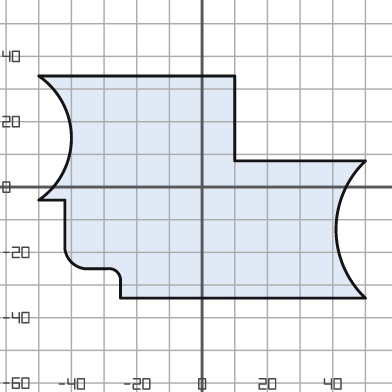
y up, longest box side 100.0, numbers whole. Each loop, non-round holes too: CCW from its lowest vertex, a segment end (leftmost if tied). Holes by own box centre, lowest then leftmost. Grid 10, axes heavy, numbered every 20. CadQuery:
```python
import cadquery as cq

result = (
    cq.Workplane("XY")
    .moveTo(-25.0, -34.0)
    .lineTo(50.0, -34.0)
    .threePointArc((41.0, -13.0), (50.0, 8.0))
    .lineTo(10.0, 8.0)
    .lineTo(10.0, 34.0)
    .lineTo(-50.0, 34.0)
    .threePointArc((-40.0, 15.0), (-50.0, -4.0))
    .lineTo(-42.0, -4.0)
    .lineTo(-42.0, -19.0)
    .threePointArc((-40.0, -23.0), (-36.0, -25.0))
    .lineTo(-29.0, -25.0)
    .threePointArc((-26.0, -26.0), (-25.0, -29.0))
    .close()
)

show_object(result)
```